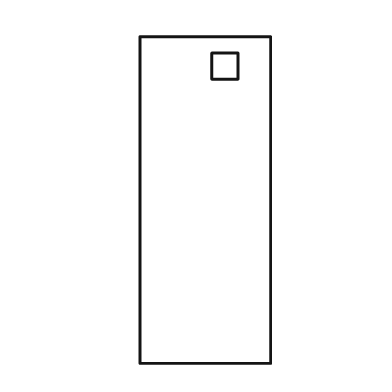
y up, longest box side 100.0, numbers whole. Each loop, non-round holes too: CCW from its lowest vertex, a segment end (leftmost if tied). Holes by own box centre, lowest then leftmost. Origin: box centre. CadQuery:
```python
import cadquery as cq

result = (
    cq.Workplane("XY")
    .moveTo(-20.0, -50.0)
    .lineTo(20.0, -50.0)
    .lineTo(20.0, 50.0)
    .lineTo(-20.0, 50.0)
    .close()
    .moveTo(2.0, 37.0)
    .lineTo(10.0, 37.0)
    .lineTo(10.0, 45.0)
    .lineTo(2.0, 45.0)
    .close()
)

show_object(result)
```